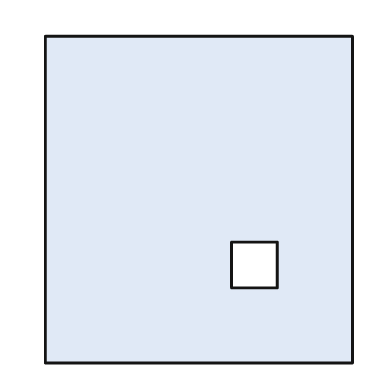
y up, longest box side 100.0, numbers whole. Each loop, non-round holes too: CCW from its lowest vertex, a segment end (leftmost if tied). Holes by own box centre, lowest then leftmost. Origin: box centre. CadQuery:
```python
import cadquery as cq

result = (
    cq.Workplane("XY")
    .moveTo(-47.0, -50.0)
    .lineTo(47.0, -50.0)
    .lineTo(47.0, 50.0)
    .lineTo(-47.0, 50.0)
    .close()
    .moveTo(10.0, -27.0)
    .lineTo(24.0, -27.0)
    .lineTo(24.0, -13.0)
    .lineTo(10.0, -13.0)
    .close()
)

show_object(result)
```